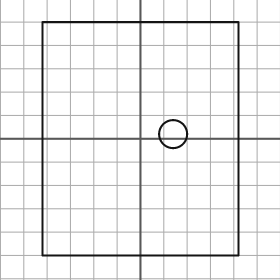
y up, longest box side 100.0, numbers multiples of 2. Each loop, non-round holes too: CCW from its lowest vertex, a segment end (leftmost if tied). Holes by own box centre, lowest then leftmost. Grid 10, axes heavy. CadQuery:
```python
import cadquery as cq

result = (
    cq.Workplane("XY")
    .moveTo(-42.0, -50.0)
    .lineTo(42.0, -50.0)
    .lineTo(42.0, 50.0)
    .lineTo(-42.0, 50.0)
    .close()
    .moveTo(14.0, 2.0)
    .circle(6.0)
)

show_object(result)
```